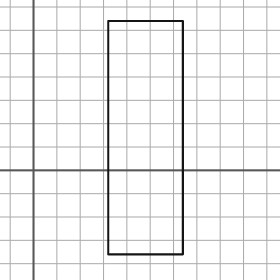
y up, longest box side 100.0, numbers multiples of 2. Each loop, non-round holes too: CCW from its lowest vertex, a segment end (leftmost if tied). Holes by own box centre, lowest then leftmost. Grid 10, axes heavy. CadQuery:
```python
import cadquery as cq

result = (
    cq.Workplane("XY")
    .moveTo(32.0, -36.0)
    .lineTo(64.0, -36.0)
    .lineTo(64.0, 64.0)
    .lineTo(32.0, 64.0)
    .close()
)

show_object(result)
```